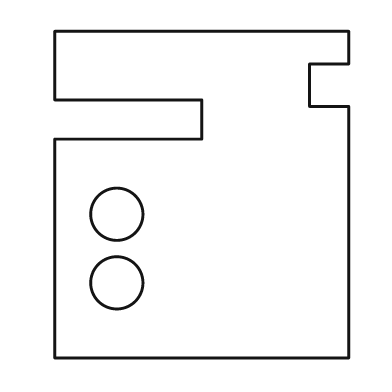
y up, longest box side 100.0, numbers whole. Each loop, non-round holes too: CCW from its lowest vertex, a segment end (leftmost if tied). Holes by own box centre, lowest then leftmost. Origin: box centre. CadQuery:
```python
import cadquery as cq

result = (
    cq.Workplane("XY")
    .moveTo(-45.0, -50.0)
    .lineTo(45.0, -50.0)
    .lineTo(45.0, 27.0)
    .lineTo(33.0, 27.0)
    .lineTo(33.0, 40.0)
    .lineTo(45.0, 40.0)
    .lineTo(45.0, 50.0)
    .lineTo(-45.0, 50.0)
    .lineTo(-45.0, 29.0)
    .lineTo(0.0, 29.0)
    .lineTo(0.0, 17.0)
    .lineTo(-45.0, 17.0)
    .close()
    .moveTo(-26.0, -27.0)
    .circle(8.0)
    .moveTo(-26.0, -6.0)
    .circle(8.0)
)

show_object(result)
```